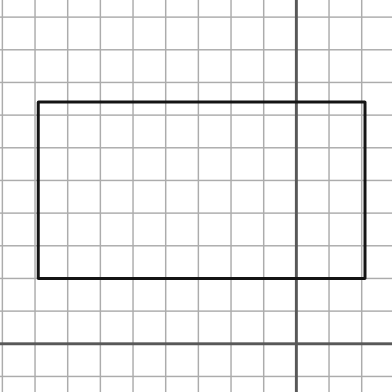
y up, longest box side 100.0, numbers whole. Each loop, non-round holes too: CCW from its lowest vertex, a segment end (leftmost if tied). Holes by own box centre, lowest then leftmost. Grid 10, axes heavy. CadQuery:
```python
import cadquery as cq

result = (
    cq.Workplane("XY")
    .moveTo(-79.0, 20.0)
    .lineTo(21.0, 20.0)
    .lineTo(21.0, 74.0)
    .lineTo(-79.0, 74.0)
    .close()
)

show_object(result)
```